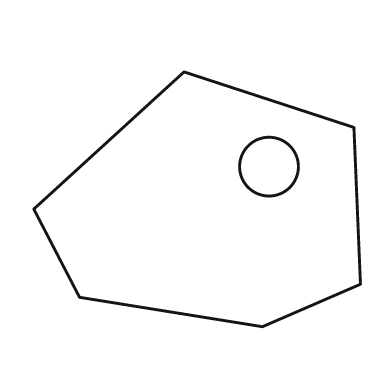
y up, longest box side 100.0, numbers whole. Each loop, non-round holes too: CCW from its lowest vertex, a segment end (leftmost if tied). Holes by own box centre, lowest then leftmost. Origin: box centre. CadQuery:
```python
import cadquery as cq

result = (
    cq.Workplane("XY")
    .moveTo(20.0, -39.0)
    .lineTo(50.0, -26.0)
    .lineTo(48.0, 22.0)
    .lineTo(-4.0, 39.0)
    .lineTo(-50.0, -3.0)
    .lineTo(-36.0, -30.0)
    .close()
    .moveTo(22.0, 10.0)
    .circle(9.0)
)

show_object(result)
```